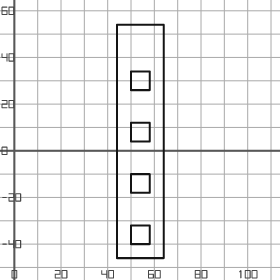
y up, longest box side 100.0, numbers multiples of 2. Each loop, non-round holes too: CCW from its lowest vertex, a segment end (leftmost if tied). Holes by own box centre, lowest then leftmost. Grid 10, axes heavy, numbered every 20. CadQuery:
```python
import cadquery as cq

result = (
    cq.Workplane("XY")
    .moveTo(44.0, -46.0)
    .lineTo(64.0, -46.0)
    .lineTo(64.0, 54.0)
    .lineTo(44.0, 54.0)
    .close()
    .moveTo(50.0, -40.0)
    .lineTo(58.0, -40.0)
    .lineTo(58.0, -32.0)
    .lineTo(50.0, -32.0)
    .close()
    .moveTo(50.0, -18.0)
    .lineTo(58.0, -18.0)
    .lineTo(58.0, -10.0)
    .lineTo(50.0, -10.0)
    .close()
    .moveTo(50.0, 4.0)
    .lineTo(58.0, 4.0)
    .lineTo(58.0, 12.0)
    .lineTo(50.0, 12.0)
    .close()
    .moveTo(50.0, 26.0)
    .lineTo(58.0, 26.0)
    .lineTo(58.0, 34.0)
    .lineTo(50.0, 34.0)
    .close()
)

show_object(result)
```